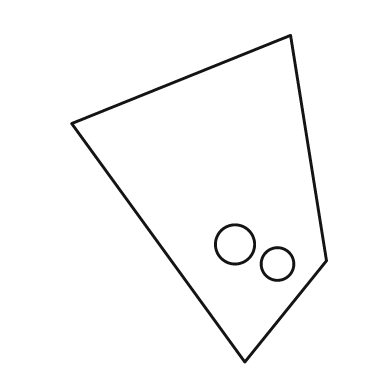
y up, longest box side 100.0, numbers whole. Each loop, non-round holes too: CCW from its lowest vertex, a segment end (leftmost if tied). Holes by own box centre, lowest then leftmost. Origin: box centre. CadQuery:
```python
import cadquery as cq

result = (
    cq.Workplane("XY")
    .moveTo(14.0, -50.0)
    .lineTo(39.0, -19.0)
    .lineTo(28.0, 50.0)
    .lineTo(-39.0, 23.0)
    .close()
    .moveTo(24.0, -20.0)
    .circle(5.0)
    .moveTo(11.0, -14.0)
    .circle(6.0)
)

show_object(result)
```